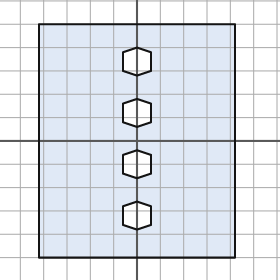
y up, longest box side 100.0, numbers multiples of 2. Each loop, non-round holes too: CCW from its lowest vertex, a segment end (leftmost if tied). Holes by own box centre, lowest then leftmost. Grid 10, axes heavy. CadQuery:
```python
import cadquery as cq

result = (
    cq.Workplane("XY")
    .moveTo(-42.0, -50.0)
    .lineTo(42.0, -50.0)
    .lineTo(42.0, 50.0)
    .lineTo(-42.0, 50.0)
    .close()
    .moveTo(0.0, -38.0)
    .lineTo(6.0, -36.0)
    .lineTo(6.0, -28.0)
    .lineTo(0.0, -26.0)
    .lineTo(-6.0, -28.0)
    .lineTo(-6.0, -36.0)
    .close()
    .moveTo(0.0, -16.0)
    .lineTo(6.0, -14.0)
    .lineTo(6.0, -6.0)
    .lineTo(0.0, -4.0)
    .lineTo(-6.0, -6.0)
    .lineTo(-6.0, -14.0)
    .close()
    .moveTo(0.0, 6.0)
    .lineTo(6.0, 8.0)
    .lineTo(6.0, 16.0)
    .lineTo(0.0, 18.0)
    .lineTo(-6.0, 16.0)
    .lineTo(-6.0, 8.0)
    .close()
    .moveTo(0.0, 28.0)
    .lineTo(6.0, 30.0)
    .lineTo(6.0, 38.0)
    .lineTo(0.0, 40.0)
    .lineTo(-6.0, 38.0)
    .lineTo(-6.0, 30.0)
    .close()
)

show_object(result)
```